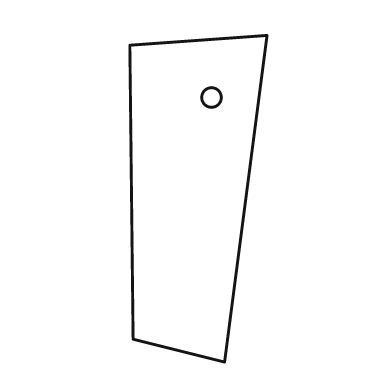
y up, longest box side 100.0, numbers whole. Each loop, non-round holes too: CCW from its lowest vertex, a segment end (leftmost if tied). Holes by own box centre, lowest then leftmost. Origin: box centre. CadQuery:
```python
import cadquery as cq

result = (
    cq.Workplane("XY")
    .moveTo(8.0, -50.0)
    .lineTo(21.0, 50.0)
    .lineTo(-21.0, 47.0)
    .lineTo(-20.0, -43.0)
    .close()
    .moveTo(4.0, 31.0)
    .circle(3.0)
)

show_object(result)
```